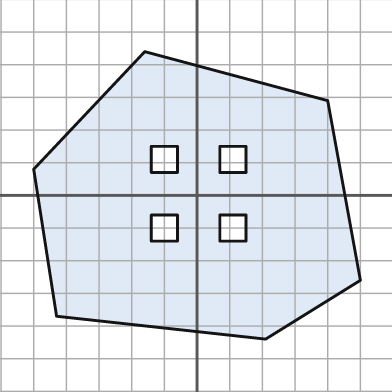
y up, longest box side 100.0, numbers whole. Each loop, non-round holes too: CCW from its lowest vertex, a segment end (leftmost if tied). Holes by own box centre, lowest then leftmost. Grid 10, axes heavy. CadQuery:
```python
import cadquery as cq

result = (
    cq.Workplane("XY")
    .moveTo(21.0, -44.0)
    .lineTo(50.0, -26.0)
    .lineTo(40.0, 29.0)
    .lineTo(-16.0, 44.0)
    .lineTo(-50.0, 8.0)
    .lineTo(-43.0, -37.0)
    .close()
    .moveTo(-14.0, -14.0)
    .lineTo(-6.0, -14.0)
    .lineTo(-6.0, -6.0)
    .lineTo(-14.0, -6.0)
    .close()
    .moveTo(7.0, -14.0)
    .lineTo(15.0, -14.0)
    .lineTo(15.0, -6.0)
    .lineTo(7.0, -6.0)
    .close()
    .moveTo(-14.0, 7.0)
    .lineTo(-6.0, 7.0)
    .lineTo(-6.0, 15.0)
    .lineTo(-14.0, 15.0)
    .close()
    .moveTo(7.0, 7.0)
    .lineTo(15.0, 7.0)
    .lineTo(15.0, 15.0)
    .lineTo(7.0, 15.0)
    .close()
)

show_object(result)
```